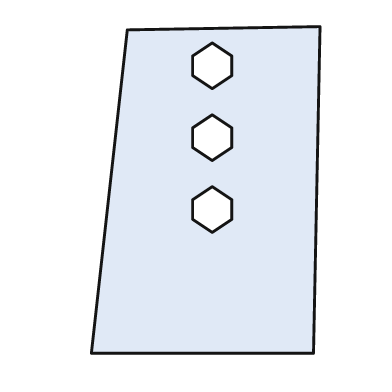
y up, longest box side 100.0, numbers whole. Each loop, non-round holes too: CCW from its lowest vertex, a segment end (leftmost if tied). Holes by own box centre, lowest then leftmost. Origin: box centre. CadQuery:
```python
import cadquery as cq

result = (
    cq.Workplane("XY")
    .moveTo(-35.0, -50.0)
    .lineTo(33.0, -50.0)
    .lineTo(35.0, 50.0)
    .lineTo(-24.0, 49.0)
    .close()
    .moveTo(2.0, -13.0)
    .lineTo(8.0, -9.0)
    .lineTo(8.0, -3.0)
    .lineTo(2.0, 1.0)
    .lineTo(-4.0, -3.0)
    .lineTo(-4.0, -9.0)
    .close()
    .moveTo(2.0, 9.0)
    .lineTo(8.0, 13.0)
    .lineTo(8.0, 19.0)
    .lineTo(2.0, 23.0)
    .lineTo(-4.0, 19.0)
    .lineTo(-4.0, 13.0)
    .close()
    .moveTo(2.0, 31.0)
    .lineTo(8.0, 35.0)
    .lineTo(8.0, 41.0)
    .lineTo(2.0, 45.0)
    .lineTo(-4.0, 41.0)
    .lineTo(-4.0, 35.0)
    .close()
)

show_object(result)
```